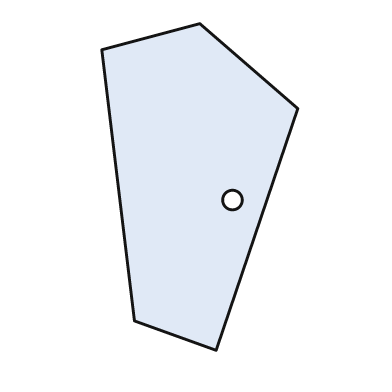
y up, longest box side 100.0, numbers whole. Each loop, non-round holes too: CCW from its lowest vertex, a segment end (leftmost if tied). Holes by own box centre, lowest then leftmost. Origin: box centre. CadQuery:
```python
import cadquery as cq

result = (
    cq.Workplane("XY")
    .moveTo(5.0, -50.0)
    .lineTo(30.0, 24.0)
    .lineTo(0.0, 50.0)
    .lineTo(-30.0, 42.0)
    .lineTo(-20.0, -41.0)
    .close()
    .moveTo(10.0, -4.0)
    .circle(3.0)
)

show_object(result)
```